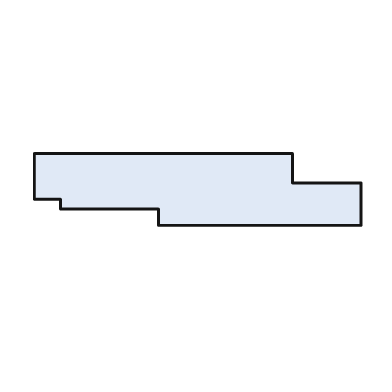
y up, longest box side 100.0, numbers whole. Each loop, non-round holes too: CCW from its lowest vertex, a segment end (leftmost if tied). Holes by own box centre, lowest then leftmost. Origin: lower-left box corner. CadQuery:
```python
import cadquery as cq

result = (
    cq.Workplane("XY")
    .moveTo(38.0, 0.0)
    .lineTo(100.0, 0.0)
    .lineTo(100.0, 13.0)
    .lineTo(79.0, 13.0)
    .lineTo(79.0, 22.0)
    .lineTo(0.0, 22.0)
    .lineTo(0.0, 8.0)
    .lineTo(8.0, 8.0)
    .lineTo(8.0, 5.0)
    .lineTo(38.0, 5.0)
    .close()
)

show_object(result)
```